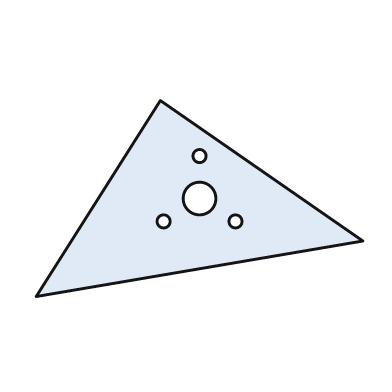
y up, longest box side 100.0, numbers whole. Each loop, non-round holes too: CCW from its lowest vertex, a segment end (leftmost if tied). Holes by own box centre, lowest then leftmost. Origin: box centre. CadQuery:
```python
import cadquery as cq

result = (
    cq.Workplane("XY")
    .moveTo(-50.0, -30.0)
    .lineTo(50.0, -13.0)
    .lineTo(-12.0, 30.0)
    .close()
    .moveTo(-11.0, -7.0)
    .circle(2.0)
    .moveTo(11.0, -7.0)
    .circle(2.0)
    .moveTo(0.0, 0.0)
    .circle(5.0)
    .moveTo(0.0, 13.0)
    .circle(2.0)
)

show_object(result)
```